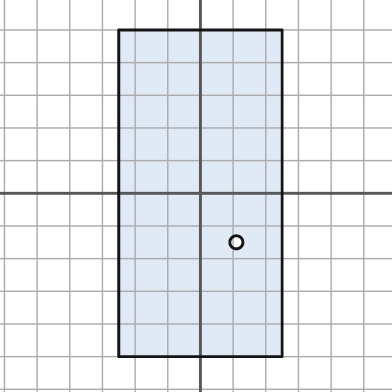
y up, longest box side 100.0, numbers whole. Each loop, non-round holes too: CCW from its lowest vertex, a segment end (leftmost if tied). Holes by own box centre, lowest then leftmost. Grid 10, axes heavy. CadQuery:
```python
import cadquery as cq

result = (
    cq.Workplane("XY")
    .moveTo(-25.0, -50.0)
    .lineTo(25.0, -50.0)
    .lineTo(25.0, 50.0)
    .lineTo(-25.0, 50.0)
    .close()
    .moveTo(11.0, -15.0)
    .circle(2.0)
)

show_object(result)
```